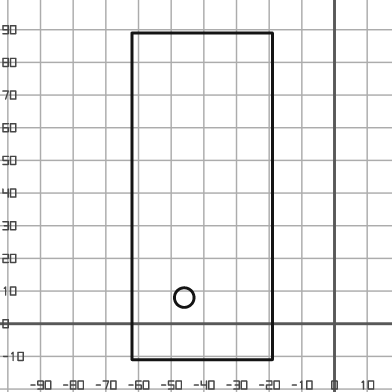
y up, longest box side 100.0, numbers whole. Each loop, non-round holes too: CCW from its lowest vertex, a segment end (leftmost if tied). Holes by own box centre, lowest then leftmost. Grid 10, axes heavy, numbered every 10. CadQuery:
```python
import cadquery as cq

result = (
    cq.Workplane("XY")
    .moveTo(-62.0, -11.0)
    .lineTo(-19.0, -11.0)
    .lineTo(-19.0, 89.0)
    .lineTo(-62.0, 89.0)
    .close()
    .moveTo(-46.0, 8.0)
    .circle(3.0)
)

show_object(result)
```